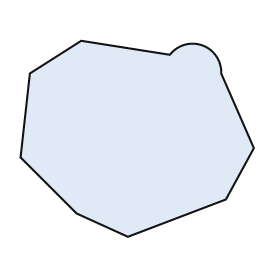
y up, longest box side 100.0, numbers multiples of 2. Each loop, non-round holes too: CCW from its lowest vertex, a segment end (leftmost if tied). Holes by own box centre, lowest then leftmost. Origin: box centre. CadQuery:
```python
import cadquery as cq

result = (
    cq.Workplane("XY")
    .moveTo(-4.0, -42.0)
    .lineTo(38.0, -26.0)
    .lineTo(50.0, -4.0)
    .lineTo(36.0, 28.0)
    .threePointArc((28.0, 40.0), (14.0, 36.0))
    .lineTo(-24.0, 42.0)
    .lineTo(-46.0, 28.0)
    .lineTo(-50.0, -8.0)
    .lineTo(-26.0, -32.0)
    .close()
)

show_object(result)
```